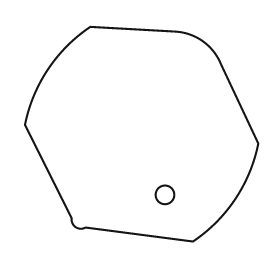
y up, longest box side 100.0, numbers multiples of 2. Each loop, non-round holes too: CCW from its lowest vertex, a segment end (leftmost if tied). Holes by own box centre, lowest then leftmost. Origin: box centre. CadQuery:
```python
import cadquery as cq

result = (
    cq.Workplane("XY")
    .moveTo(22.0, -46.0)
    .threePointArc((40.0, -28.0), (50.0, -4.0))
    .lineTo(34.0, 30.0)
    .threePointArc((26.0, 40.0), (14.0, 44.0))
    .lineTo(-22.0, 46.0)
    .threePointArc((-40.0, 28.0), (-50.0, 4.0))
    .lineTo(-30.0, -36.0)
    .threePointArc((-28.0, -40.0), (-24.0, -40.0))
    .close()
    .moveTo(10.0, -26.0)
    .circle(4.0)
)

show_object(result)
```